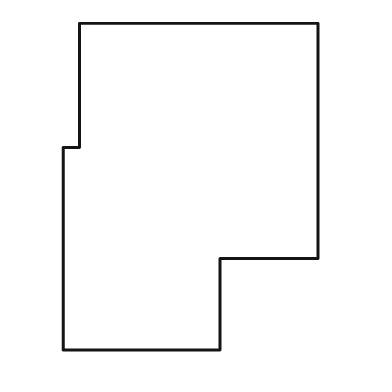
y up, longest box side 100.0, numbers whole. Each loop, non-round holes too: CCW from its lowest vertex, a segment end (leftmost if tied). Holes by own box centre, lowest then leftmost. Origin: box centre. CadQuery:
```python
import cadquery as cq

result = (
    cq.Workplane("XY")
    .moveTo(-39.0, -50.0)
    .lineTo(9.0, -50.0)
    .lineTo(9.0, -22.0)
    .lineTo(39.0, -22.0)
    .lineTo(39.0, 50.0)
    .lineTo(-34.0, 50.0)
    .lineTo(-34.0, 12.0)
    .lineTo(-39.0, 12.0)
    .close()
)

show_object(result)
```